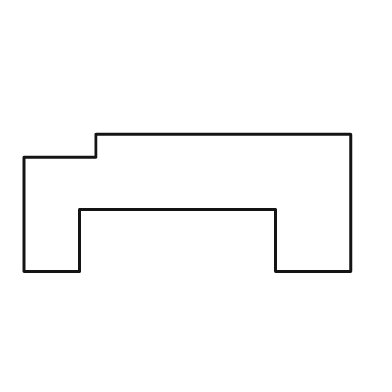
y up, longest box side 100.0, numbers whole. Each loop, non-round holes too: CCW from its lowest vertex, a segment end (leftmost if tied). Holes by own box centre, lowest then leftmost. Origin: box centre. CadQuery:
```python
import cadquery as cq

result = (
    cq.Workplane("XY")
    .moveTo(-50.0, -21.0)
    .lineTo(-33.0, -21.0)
    .lineTo(-33.0, -2.0)
    .lineTo(27.0, -2.0)
    .lineTo(27.0, -21.0)
    .lineTo(50.0, -21.0)
    .lineTo(50.0, 21.0)
    .lineTo(-28.0, 21.0)
    .lineTo(-28.0, 14.0)
    .lineTo(-50.0, 14.0)
    .close()
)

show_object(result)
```